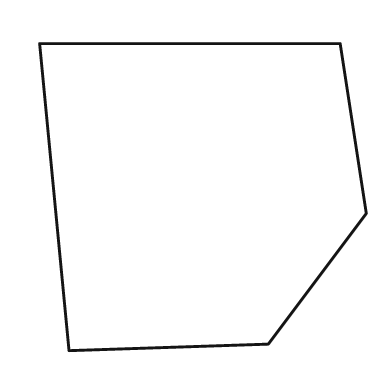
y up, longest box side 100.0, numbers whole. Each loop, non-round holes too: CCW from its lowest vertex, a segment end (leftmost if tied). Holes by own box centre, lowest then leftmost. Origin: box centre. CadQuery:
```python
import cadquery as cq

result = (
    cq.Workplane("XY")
    .moveTo(-41.0, -47.0)
    .lineTo(20.0, -45.0)
    .lineTo(50.0, -5.0)
    .lineTo(42.0, 47.0)
    .lineTo(-50.0, 47.0)
    .close()
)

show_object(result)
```